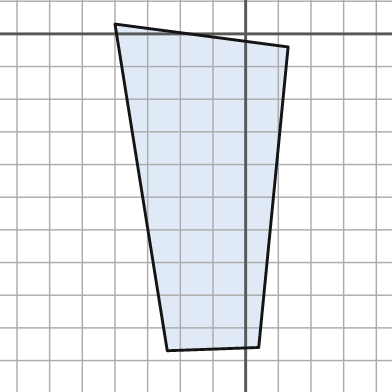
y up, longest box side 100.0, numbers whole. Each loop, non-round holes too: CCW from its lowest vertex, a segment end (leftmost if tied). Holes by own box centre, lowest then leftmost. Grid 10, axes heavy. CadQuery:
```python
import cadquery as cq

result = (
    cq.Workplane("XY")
    .moveTo(-24.0, -97.0)
    .lineTo(4.0, -96.0)
    .lineTo(13.0, -4.0)
    .lineTo(-40.0, 3.0)
    .close()
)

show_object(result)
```